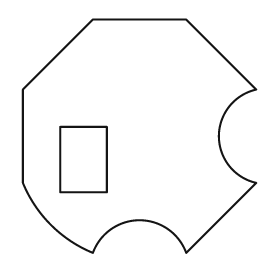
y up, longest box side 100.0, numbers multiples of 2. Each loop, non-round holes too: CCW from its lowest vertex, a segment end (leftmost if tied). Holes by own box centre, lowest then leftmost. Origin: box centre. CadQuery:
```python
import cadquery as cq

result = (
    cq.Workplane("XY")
    .moveTo(-20.0, -50.0)
    .threePointArc((0.0, -36.0), (20.0, -50.0))
    .lineTo(50.0, -20.0)
    .threePointArc((34.0, 0.0), (50.0, 20.0))
    .lineTo(20.0, 50.0)
    .lineTo(-20.0, 50.0)
    .lineTo(-50.0, 20.0)
    .lineTo(-50.0, -20.0)
    .threePointArc((-38.0, -38.0), (-20.0, -50.0))
    .close()
    .moveTo(-34.0, -24.0)
    .lineTo(-14.0, -24.0)
    .lineTo(-14.0, 4.0)
    .lineTo(-34.0, 4.0)
    .close()
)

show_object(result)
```